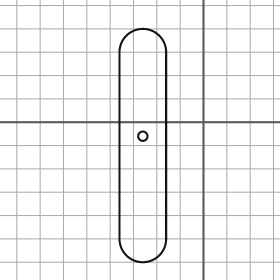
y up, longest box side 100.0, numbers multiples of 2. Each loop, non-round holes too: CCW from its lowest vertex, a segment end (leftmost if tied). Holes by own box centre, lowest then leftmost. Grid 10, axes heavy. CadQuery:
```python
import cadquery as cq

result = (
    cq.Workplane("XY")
    .moveTo(-36.0, -50.0)
    .threePointArc((-26.0, -60.0), (-16.0, -50.0))
    .lineTo(-16.0, 30.0)
    .threePointArc((-26.0, 40.0), (-36.0, 30.0))
    .close()
    .moveTo(-26.0, -6.0)
    .circle(2.0)
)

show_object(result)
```